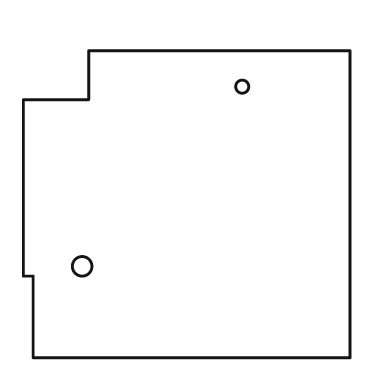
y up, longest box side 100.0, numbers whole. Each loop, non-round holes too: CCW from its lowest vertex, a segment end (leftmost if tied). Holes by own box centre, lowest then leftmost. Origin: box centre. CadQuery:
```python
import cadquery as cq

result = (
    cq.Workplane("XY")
    .moveTo(-47.0, -47.0)
    .lineTo(50.0, -47.0)
    .lineTo(50.0, 47.0)
    .lineTo(-30.0, 47.0)
    .lineTo(-30.0, 32.0)
    .lineTo(-50.0, 32.0)
    .lineTo(-50.0, -22.0)
    .lineTo(-47.0, -22.0)
    .close()
    .moveTo(-32.0, -19.0)
    .circle(3.0)
    .moveTo(17.0, 36.0)
    .circle(2.0)
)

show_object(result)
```